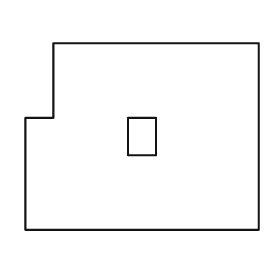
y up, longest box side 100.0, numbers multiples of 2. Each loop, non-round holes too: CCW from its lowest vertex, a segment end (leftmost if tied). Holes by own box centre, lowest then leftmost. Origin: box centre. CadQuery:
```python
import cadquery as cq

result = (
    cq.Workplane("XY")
    .moveTo(-50.0, -40.0)
    .lineTo(50.0, -40.0)
    .lineTo(50.0, 40.0)
    .lineTo(-38.0, 40.0)
    .lineTo(-38.0, 8.0)
    .lineTo(-50.0, 8.0)
    .close()
    .moveTo(-6.0, -8.0)
    .lineTo(6.0, -8.0)
    .lineTo(6.0, 8.0)
    .lineTo(-6.0, 8.0)
    .close()
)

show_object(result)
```